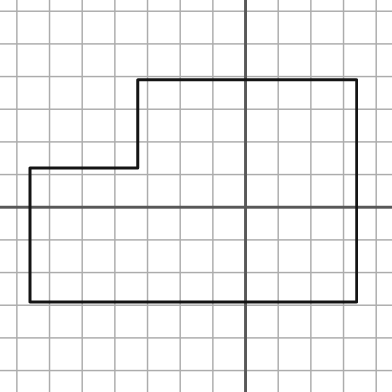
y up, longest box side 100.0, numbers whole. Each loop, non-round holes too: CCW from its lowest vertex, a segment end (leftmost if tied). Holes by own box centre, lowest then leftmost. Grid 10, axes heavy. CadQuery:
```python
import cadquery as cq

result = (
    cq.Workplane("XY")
    .moveTo(-66.0, -29.0)
    .lineTo(34.0, -29.0)
    .lineTo(34.0, 39.0)
    .lineTo(-33.0, 39.0)
    .lineTo(-33.0, 12.0)
    .lineTo(-66.0, 12.0)
    .close()
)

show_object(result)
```